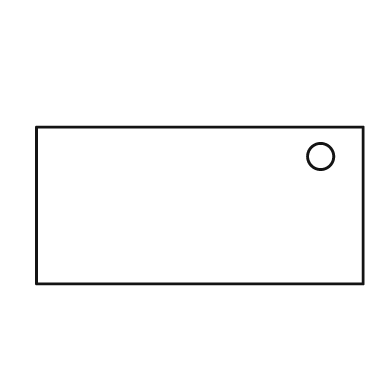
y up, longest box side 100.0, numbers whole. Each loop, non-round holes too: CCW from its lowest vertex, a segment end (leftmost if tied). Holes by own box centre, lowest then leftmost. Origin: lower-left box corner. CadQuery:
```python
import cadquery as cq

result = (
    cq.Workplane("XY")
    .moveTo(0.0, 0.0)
    .lineTo(100.0, 0.0)
    .lineTo(100.0, 48.0)
    .lineTo(0.0, 48.0)
    .close()
    .moveTo(87.0, 39.0)
    .circle(4.0)
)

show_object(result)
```